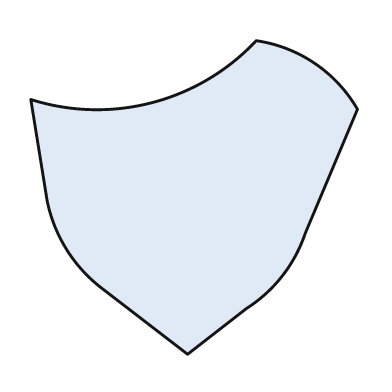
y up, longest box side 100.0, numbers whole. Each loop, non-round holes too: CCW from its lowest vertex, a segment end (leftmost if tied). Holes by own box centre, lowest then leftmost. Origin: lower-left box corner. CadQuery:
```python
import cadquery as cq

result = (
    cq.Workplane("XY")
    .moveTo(48.0, 0.0)
    .lineTo(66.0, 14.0)
    .threePointArc((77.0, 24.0), (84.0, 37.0))
    .lineTo(100.0, 75.0)
    .threePointArc((87.0, 89.0), (69.0, 96.0))
    .threePointArc((37.0, 77.0), (0.0, 78.0))
    .lineTo(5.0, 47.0)
    .threePointArc((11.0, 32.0), (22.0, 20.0))
    .close()
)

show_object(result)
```